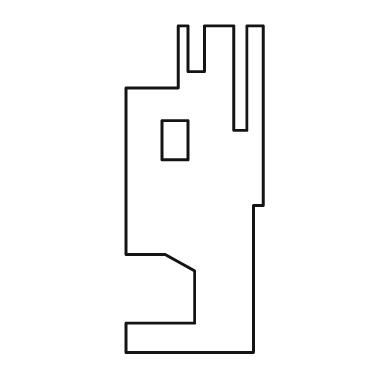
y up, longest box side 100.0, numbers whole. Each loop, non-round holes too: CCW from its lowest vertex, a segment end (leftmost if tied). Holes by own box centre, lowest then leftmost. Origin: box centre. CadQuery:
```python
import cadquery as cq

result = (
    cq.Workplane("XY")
    .moveTo(-21.0, -50.0)
    .lineTo(18.0, -50.0)
    .lineTo(18.0, -5.0)
    .lineTo(21.0, -5.0)
    .lineTo(21.0, 50.0)
    .lineTo(16.0, 50.0)
    .lineTo(16.0, 18.0)
    .lineTo(12.0, 18.0)
    .lineTo(12.0, 50.0)
    .lineTo(3.0, 50.0)
    .lineTo(3.0, 36.0)
    .lineTo(-2.0, 36.0)
    .lineTo(-2.0, 50.0)
    .lineTo(-5.0, 50.0)
    .lineTo(-5.0, 31.0)
    .lineTo(-21.0, 31.0)
    .lineTo(-21.0, -20.0)
    .lineTo(-9.0, -20.0)
    .lineTo(0.0, -25.0)
    .lineTo(0.0, -41.0)
    .lineTo(-21.0, -41.0)
    .close()
    .moveTo(-10.0, 9.0)
    .lineTo(-2.0, 9.0)
    .lineTo(-2.0, 21.0)
    .lineTo(-10.0, 21.0)
    .close()
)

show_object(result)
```